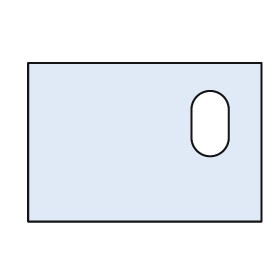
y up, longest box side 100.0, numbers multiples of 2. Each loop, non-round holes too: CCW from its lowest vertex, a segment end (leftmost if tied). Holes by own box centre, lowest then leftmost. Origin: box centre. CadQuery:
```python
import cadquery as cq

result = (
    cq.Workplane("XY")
    .moveTo(-50.0, -34.0)
    .lineTo(50.0, -34.0)
    .lineTo(50.0, 34.0)
    .lineTo(-50.0, 34.0)
    .close()
    .moveTo(20.0, 2.0)
    .threePointArc((28.0, -6.0), (36.0, 2.0))
    .lineTo(36.0, 14.0)
    .threePointArc((28.0, 22.0), (20.0, 14.0))
    .close()
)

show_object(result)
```